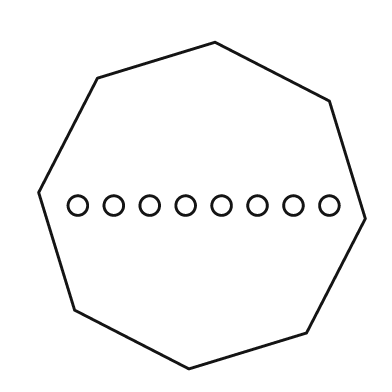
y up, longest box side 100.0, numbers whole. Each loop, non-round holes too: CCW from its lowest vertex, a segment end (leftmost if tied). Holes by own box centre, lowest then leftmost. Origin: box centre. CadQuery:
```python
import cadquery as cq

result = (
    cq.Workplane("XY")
    .moveTo(-4.0, -50.0)
    .lineTo(32.0, -39.0)
    .lineTo(50.0, -4.0)
    .lineTo(39.0, 32.0)
    .lineTo(4.0, 50.0)
    .lineTo(-32.0, 39.0)
    .lineTo(-50.0, 4.0)
    .lineTo(-39.0, -32.0)
    .close()
    .moveTo(-38.0, 0.0)
    .circle(3.0)
    .moveTo(-27.0, 0.0)
    .circle(3.0)
    .moveTo(-16.0, 0.0)
    .circle(3.0)
    .moveTo(-5.0, 0.0)
    .circle(3.0)
    .moveTo(6.0, 0.0)
    .circle(3.0)
    .moveTo(17.0, 0.0)
    .circle(3.0)
    .moveTo(28.0, 0.0)
    .circle(3.0)
    .moveTo(39.0, 0.0)
    .circle(3.0)
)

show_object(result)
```